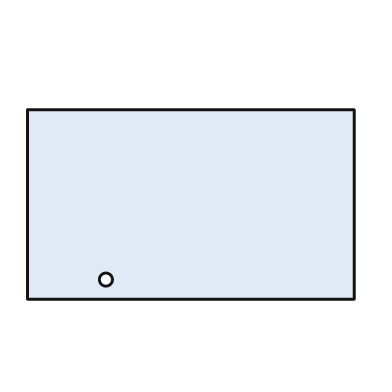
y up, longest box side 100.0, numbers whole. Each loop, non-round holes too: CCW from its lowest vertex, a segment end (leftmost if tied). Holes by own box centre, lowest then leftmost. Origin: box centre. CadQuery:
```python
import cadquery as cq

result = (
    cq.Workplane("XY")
    .moveTo(-50.0, -29.0)
    .lineTo(50.0, -29.0)
    .lineTo(50.0, 29.0)
    .lineTo(-50.0, 29.0)
    .close()
    .moveTo(-26.0, -23.0)
    .circle(2.0)
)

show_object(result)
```